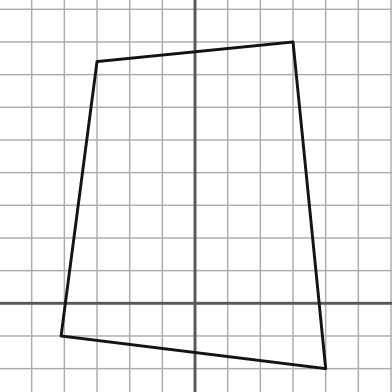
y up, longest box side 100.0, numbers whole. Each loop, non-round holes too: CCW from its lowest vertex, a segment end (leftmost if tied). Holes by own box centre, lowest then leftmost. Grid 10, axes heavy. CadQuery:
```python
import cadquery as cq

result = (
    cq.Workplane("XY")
    .moveTo(40.0, -20.0)
    .lineTo(30.0, 80.0)
    .lineTo(-30.0, 74.0)
    .lineTo(-41.0, -10.0)
    .close()
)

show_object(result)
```